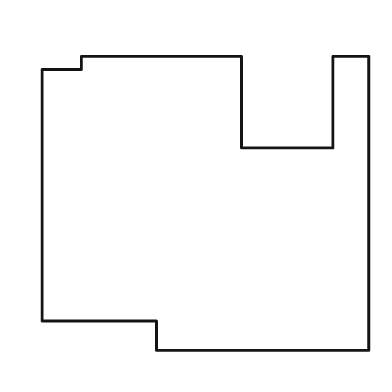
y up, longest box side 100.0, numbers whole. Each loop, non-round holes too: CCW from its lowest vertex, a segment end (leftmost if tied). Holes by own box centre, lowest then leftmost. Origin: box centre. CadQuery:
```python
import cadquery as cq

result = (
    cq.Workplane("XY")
    .moveTo(-15.0, -45.0)
    .lineTo(50.0, -45.0)
    .lineTo(50.0, 45.0)
    .lineTo(39.0, 45.0)
    .lineTo(39.0, 17.0)
    .lineTo(11.0, 17.0)
    .lineTo(11.0, 45.0)
    .lineTo(-38.0, 45.0)
    .lineTo(-38.0, 41.0)
    .lineTo(-50.0, 41.0)
    .lineTo(-50.0, -36.0)
    .lineTo(-15.0, -36.0)
    .close()
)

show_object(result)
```